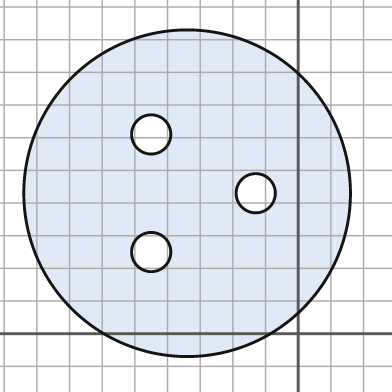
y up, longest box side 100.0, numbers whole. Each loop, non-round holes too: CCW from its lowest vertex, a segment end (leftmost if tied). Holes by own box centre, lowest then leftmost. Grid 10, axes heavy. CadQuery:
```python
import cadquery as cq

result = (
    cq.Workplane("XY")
    .moveTo(-34.0, 43.0)
    .circle(50.0)
    .moveTo(-45.0, 25.0)
    .circle(6.0)
    .moveTo(-13.0, 43.0)
    .circle(6.0)
    .moveTo(-45.0, 61.0)
    .circle(6.0)
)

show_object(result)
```